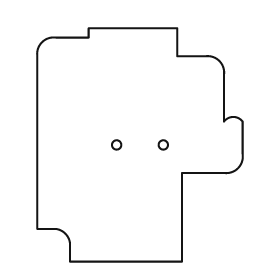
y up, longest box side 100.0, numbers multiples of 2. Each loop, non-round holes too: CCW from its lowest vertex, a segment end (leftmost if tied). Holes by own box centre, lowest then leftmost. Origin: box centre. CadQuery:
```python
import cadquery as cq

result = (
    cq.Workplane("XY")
    .moveTo(-30.0, -50.0)
    .lineTo(18.0, -50.0)
    .lineTo(18.0, -12.0)
    .lineTo(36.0, -12.0)
    .threePointArc((42.0, -10.0), (44.0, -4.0))
    .lineTo(44.0, 10.0)
    .threePointArc((40.0, 12.0), (36.0, 10.0))
    .lineTo(36.0, 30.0)
    .threePointArc((34.0, 36.0), (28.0, 38.0))
    .lineTo(16.0, 38.0)
    .lineTo(16.0, 50.0)
    .lineTo(-22.0, 50.0)
    .lineTo(-22.0, 46.0)
    .lineTo(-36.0, 46.0)
    .threePointArc((-42.0, 44.0), (-44.0, 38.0))
    .lineTo(-44.0, -36.0)
    .lineTo(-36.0, -36.0)
    .threePointArc((-32.0, -38.0), (-30.0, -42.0))
    .close()
    .moveTo(-10.0, 0.0)
    .circle(2.0)
    .moveTo(10.0, 0.0)
    .circle(2.0)
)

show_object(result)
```